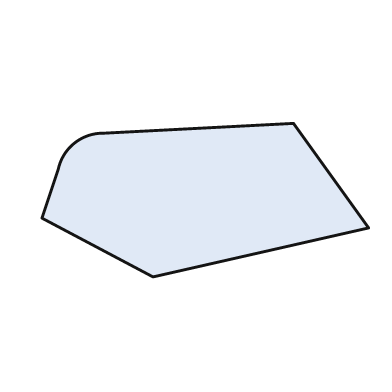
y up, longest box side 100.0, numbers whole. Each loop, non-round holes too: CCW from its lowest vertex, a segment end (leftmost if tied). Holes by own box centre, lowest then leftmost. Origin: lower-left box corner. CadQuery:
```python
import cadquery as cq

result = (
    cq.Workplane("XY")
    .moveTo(34.0, 0.0)
    .lineTo(100.0, 15.0)
    .lineTo(77.0, 47.0)
    .lineTo(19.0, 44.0)
    .threePointArc((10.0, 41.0), (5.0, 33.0))
    .lineTo(0.0, 18.0)
    .close()
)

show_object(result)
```